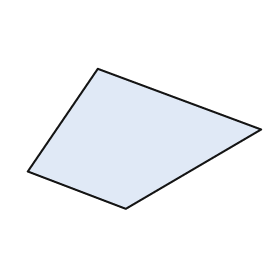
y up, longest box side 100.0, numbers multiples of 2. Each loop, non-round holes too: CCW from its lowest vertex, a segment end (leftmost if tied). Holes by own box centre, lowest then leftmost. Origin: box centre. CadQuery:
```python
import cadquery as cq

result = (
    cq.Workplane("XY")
    .moveTo(-8.0, -30.0)
    .lineTo(50.0, 4.0)
    .lineTo(-20.0, 30.0)
    .lineTo(-50.0, -14.0)
    .close()
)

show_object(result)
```